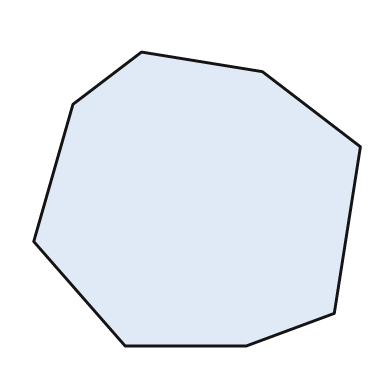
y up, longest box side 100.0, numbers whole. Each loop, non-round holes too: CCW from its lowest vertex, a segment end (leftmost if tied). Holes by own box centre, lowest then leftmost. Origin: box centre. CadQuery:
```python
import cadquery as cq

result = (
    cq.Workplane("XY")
    .moveTo(-22.0, -45.0)
    .lineTo(15.0, -45.0)
    .lineTo(42.0, -35.0)
    .lineTo(50.0, 16.0)
    .lineTo(20.0, 39.0)
    .lineTo(-17.0, 45.0)
    .lineTo(-38.0, 29.0)
    .lineTo(-50.0, -13.0)
    .close()
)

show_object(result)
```